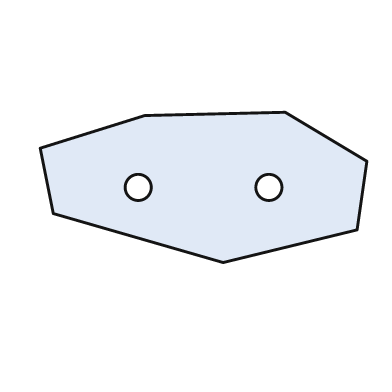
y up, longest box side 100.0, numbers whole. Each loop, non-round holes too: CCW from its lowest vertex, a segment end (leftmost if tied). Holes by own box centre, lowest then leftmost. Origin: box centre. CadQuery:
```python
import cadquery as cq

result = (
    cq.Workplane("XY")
    .moveTo(6.0, -23.0)
    .lineTo(47.0, -13.0)
    .lineTo(50.0, 8.0)
    .lineTo(25.0, 23.0)
    .lineTo(-18.0, 22.0)
    .lineTo(-50.0, 12.0)
    .lineTo(-46.0, -8.0)
    .close()
    .moveTo(-20.0, 0.0)
    .circle(4.0)
    .moveTo(20.0, 0.0)
    .circle(4.0)
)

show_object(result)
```